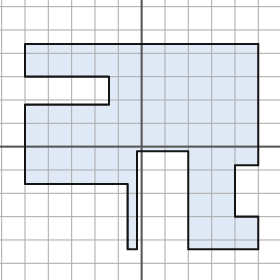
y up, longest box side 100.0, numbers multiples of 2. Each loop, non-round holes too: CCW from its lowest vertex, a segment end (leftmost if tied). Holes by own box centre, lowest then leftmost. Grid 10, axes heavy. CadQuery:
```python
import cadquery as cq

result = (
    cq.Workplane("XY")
    .moveTo(-6.0, -44.0)
    .lineTo(-2.0, -44.0)
    .lineTo(-2.0, -2.0)
    .lineTo(20.0, -2.0)
    .lineTo(20.0, -44.0)
    .lineTo(50.0, -44.0)
    .lineTo(50.0, -30.0)
    .lineTo(40.0, -30.0)
    .lineTo(40.0, -8.0)
    .lineTo(50.0, -8.0)
    .lineTo(50.0, 44.0)
    .lineTo(-50.0, 44.0)
    .lineTo(-50.0, 30.0)
    .lineTo(-14.0, 30.0)
    .lineTo(-14.0, 18.0)
    .lineTo(-50.0, 18.0)
    .lineTo(-50.0, -16.0)
    .lineTo(-6.0, -16.0)
    .close()
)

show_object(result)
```